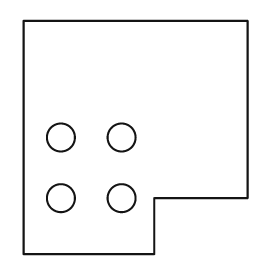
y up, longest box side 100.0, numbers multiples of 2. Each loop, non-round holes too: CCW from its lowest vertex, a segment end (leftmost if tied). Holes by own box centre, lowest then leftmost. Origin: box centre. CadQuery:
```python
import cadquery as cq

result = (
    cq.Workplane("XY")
    .moveTo(-48.0, -50.0)
    .lineTo(8.0, -50.0)
    .lineTo(8.0, -26.0)
    .lineTo(48.0, -26.0)
    .lineTo(48.0, 50.0)
    .lineTo(-48.0, 50.0)
    .close()
    .moveTo(-32.0, -26.0)
    .circle(6.0)
    .moveTo(-6.0, -26.0)
    .circle(6.0)
    .moveTo(-32.0, 0.0)
    .circle(6.0)
    .moveTo(-6.0, 0.0)
    .circle(6.0)
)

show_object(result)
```